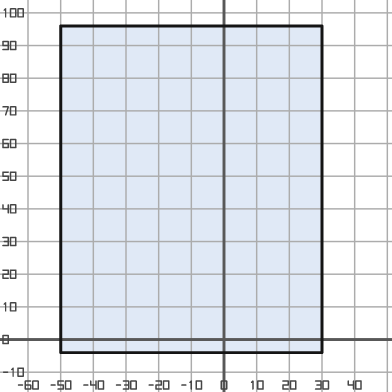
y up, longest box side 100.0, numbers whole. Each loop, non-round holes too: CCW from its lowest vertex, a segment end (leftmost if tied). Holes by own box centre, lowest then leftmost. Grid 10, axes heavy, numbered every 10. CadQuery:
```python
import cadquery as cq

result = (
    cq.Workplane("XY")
    .moveTo(-50.0, -4.0)
    .lineTo(30.0, -4.0)
    .lineTo(30.0, 96.0)
    .lineTo(-50.0, 96.0)
    .close()
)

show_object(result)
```